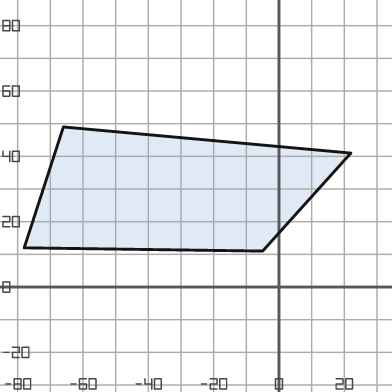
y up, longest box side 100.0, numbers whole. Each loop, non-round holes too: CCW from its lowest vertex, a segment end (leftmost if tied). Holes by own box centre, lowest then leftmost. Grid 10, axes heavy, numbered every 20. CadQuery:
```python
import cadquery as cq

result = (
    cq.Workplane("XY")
    .moveTo(-5.0, 11.0)
    .lineTo(22.0, 41.0)
    .lineTo(-66.0, 49.0)
    .lineTo(-78.0, 12.0)
    .close()
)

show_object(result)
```